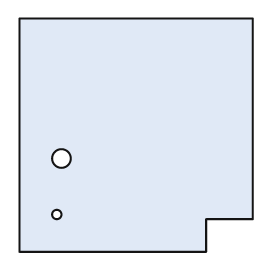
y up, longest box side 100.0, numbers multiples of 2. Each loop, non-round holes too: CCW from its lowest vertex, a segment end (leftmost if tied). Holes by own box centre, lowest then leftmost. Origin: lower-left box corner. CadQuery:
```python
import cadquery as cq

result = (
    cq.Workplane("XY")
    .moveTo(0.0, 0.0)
    .lineTo(80.0, 0.0)
    .lineTo(80.0, 14.0)
    .lineTo(100.0, 14.0)
    .lineTo(100.0, 100.0)
    .lineTo(0.0, 100.0)
    .close()
    .moveTo(16.0, 16.0)
    .circle(2.0)
    .moveTo(18.0, 40.0)
    .circle(4.0)
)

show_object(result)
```